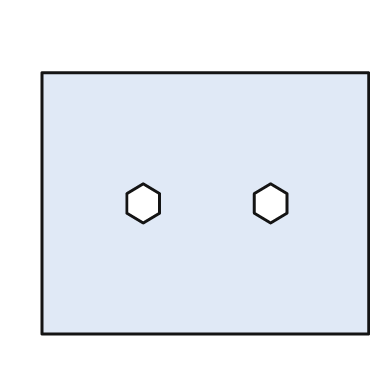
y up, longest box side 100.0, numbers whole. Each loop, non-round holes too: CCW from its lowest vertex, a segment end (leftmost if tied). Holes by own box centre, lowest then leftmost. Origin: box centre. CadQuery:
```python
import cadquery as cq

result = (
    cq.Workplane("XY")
    .moveTo(-50.0, -40.0)
    .lineTo(50.0, -40.0)
    .lineTo(50.0, 40.0)
    .lineTo(-50.0, 40.0)
    .close()
    .moveTo(-19.0, -6.0)
    .lineTo(-14.0, -3.0)
    .lineTo(-14.0, 3.0)
    .lineTo(-19.0, 6.0)
    .lineTo(-24.0, 3.0)
    .lineTo(-24.0, -3.0)
    .close()
    .moveTo(20.0, -6.0)
    .lineTo(25.0, -3.0)
    .lineTo(25.0, 3.0)
    .lineTo(20.0, 6.0)
    .lineTo(15.0, 3.0)
    .lineTo(15.0, -3.0)
    .close()
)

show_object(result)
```